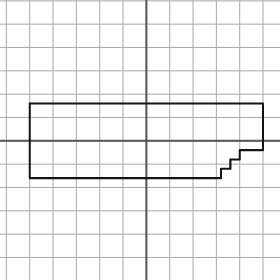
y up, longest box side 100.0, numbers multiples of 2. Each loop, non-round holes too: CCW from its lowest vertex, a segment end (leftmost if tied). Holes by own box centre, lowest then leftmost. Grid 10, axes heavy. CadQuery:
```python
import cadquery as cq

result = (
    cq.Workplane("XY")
    .moveTo(-50.0, -16.0)
    .lineTo(32.0, -16.0)
    .lineTo(32.0, -12.0)
    .lineTo(36.0, -12.0)
    .lineTo(36.0, -8.0)
    .lineTo(40.0, -8.0)
    .lineTo(40.0, -4.0)
    .lineTo(50.0, -4.0)
    .lineTo(50.0, 16.0)
    .lineTo(-50.0, 16.0)
    .close()
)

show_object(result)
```